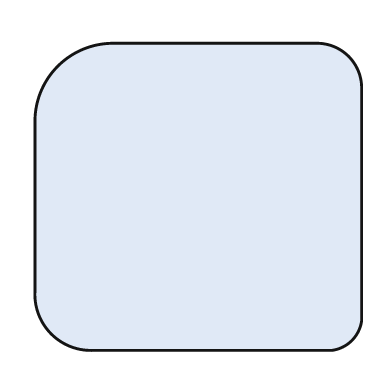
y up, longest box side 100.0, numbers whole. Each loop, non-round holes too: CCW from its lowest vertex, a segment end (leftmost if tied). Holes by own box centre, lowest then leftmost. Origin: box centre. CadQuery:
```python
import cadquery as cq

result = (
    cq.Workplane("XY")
    .moveTo(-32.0, -47.0)
    .lineTo(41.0, -47.0)
    .threePointArc((47.0, -44.0), (50.0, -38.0))
    .lineTo(50.0, 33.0)
    .threePointArc((46.0, 43.0), (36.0, 47.0))
    .lineTo(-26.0, 47.0)
    .threePointArc((-43.0, 40.0), (-50.0, 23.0))
    .lineTo(-50.0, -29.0)
    .threePointArc((-45.0, -42.0), (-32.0, -47.0))
    .close()
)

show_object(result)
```